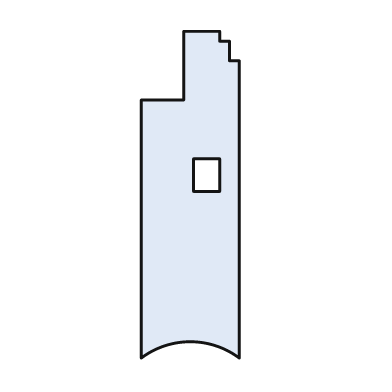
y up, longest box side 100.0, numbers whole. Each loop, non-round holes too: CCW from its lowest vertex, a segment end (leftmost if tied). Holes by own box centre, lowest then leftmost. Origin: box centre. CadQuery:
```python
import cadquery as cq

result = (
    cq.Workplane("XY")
    .moveTo(-15.0, -50.0)
    .threePointArc((0.0, -45.0), (15.0, -50.0))
    .lineTo(15.0, 41.0)
    .lineTo(12.0, 41.0)
    .lineTo(12.0, 47.0)
    .lineTo(9.0, 47.0)
    .lineTo(9.0, 50.0)
    .lineTo(-2.0, 50.0)
    .lineTo(-2.0, 29.0)
    .lineTo(-15.0, 29.0)
    .close()
    .moveTo(1.0, 1.0)
    .lineTo(9.0, 1.0)
    .lineTo(9.0, 11.0)
    .lineTo(1.0, 11.0)
    .close()
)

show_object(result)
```